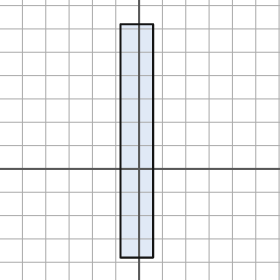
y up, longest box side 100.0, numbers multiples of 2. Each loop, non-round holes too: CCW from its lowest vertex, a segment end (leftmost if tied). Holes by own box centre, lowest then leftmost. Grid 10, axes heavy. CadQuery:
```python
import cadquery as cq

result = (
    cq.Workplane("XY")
    .moveTo(-8.0, -38.0)
    .lineTo(6.0, -38.0)
    .lineTo(6.0, 62.0)
    .lineTo(-8.0, 62.0)
    .close()
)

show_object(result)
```